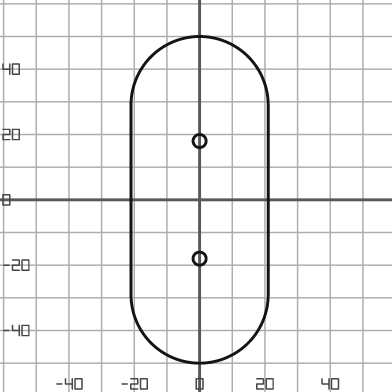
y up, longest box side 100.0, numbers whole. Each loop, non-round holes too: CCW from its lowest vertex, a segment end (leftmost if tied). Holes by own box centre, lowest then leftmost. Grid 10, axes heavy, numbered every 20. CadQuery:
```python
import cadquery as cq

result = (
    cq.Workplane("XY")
    .moveTo(-21.0, -29.0)
    .threePointArc((0.0, -50.0), (21.0, -29.0))
    .lineTo(21.0, 29.0)
    .threePointArc((0.0, 50.0), (-21.0, 29.0))
    .close()
    .moveTo(0.0, -18.0)
    .circle(2.0)
    .moveTo(0.0, 18.0)
    .circle(2.0)
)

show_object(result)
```